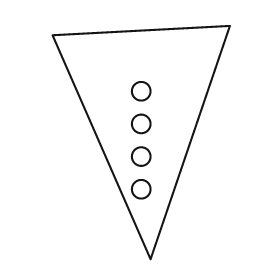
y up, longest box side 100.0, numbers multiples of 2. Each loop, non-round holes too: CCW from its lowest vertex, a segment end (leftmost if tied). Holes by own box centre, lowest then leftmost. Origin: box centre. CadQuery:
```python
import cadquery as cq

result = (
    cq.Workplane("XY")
    .moveTo(4.0, -50.0)
    .lineTo(38.0, 50.0)
    .lineTo(-38.0, 46.0)
    .close()
    .moveTo(0.0, -20.0)
    .circle(4.0)
    .moveTo(0.0, -6.0)
    .circle(4.0)
    .moveTo(0.0, 8.0)
    .circle(4.0)
    .moveTo(0.0, 22.0)
    .circle(4.0)
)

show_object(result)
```